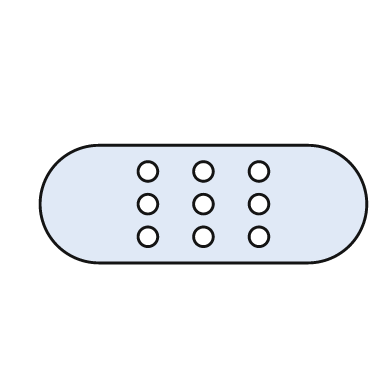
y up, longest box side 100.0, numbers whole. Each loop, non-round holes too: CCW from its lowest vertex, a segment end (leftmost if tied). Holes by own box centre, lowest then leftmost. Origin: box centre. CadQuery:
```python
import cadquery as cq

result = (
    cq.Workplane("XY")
    .moveTo(-32.0, -18.0)
    .lineTo(32.0, -18.0)
    .threePointArc((50.0, 0.0), (32.0, 18.0))
    .lineTo(-32.0, 18.0)
    .threePointArc((-50.0, 0.0), (-32.0, -18.0))
    .close()
    .moveTo(-17.0, -10.0)
    .circle(3.0)
    .moveTo(0.0, -10.0)
    .circle(3.0)
    .moveTo(17.0, -10.0)
    .circle(3.0)
    .moveTo(-17.0, 0.0)
    .circle(3.0)
    .moveTo(0.0, 0.0)
    .circle(3.0)
    .moveTo(17.0, 0.0)
    .circle(3.0)
    .moveTo(-17.0, 10.0)
    .circle(3.0)
    .moveTo(0.0, 10.0)
    .circle(3.0)
    .moveTo(17.0, 10.0)
    .circle(3.0)
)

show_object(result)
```